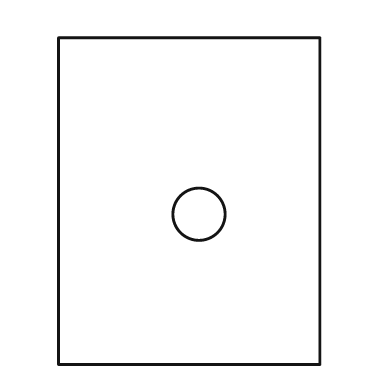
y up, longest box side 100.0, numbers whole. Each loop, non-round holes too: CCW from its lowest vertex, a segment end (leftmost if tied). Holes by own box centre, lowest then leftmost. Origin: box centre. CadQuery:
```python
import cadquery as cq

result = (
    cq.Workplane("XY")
    .moveTo(-40.0, -50.0)
    .lineTo(40.0, -50.0)
    .lineTo(40.0, 50.0)
    .lineTo(-40.0, 50.0)
    .close()
    .moveTo(3.0, -4.0)
    .circle(8.0)
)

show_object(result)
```